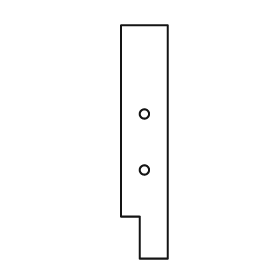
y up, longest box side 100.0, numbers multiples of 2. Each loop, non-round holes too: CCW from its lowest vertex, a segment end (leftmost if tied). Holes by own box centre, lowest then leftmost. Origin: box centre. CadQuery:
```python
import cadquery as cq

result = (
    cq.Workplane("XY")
    .moveTo(-2.0, -50.0)
    .lineTo(10.0, -50.0)
    .lineTo(10.0, 50.0)
    .lineTo(-10.0, 50.0)
    .lineTo(-10.0, -32.0)
    .lineTo(-2.0, -32.0)
    .close()
    .moveTo(0.0, -12.0)
    .circle(2.0)
    .moveTo(0.0, 12.0)
    .circle(2.0)
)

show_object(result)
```